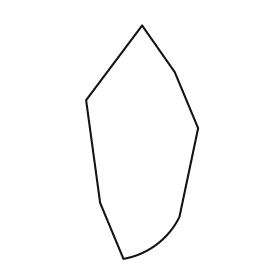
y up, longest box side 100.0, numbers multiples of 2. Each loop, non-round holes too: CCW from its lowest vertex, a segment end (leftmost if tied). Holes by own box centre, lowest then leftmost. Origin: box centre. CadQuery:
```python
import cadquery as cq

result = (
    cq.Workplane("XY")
    .moveTo(-8.0, -50.0)
    .threePointArc((6.0, -44.0), (16.0, -32.0))
    .lineTo(24.0, 6.0)
    .lineTo(14.0, 30.0)
    .lineTo(0.0, 50.0)
    .lineTo(-24.0, 18.0)
    .lineTo(-18.0, -26.0)
    .close()
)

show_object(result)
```